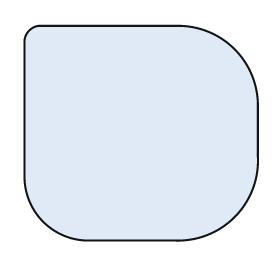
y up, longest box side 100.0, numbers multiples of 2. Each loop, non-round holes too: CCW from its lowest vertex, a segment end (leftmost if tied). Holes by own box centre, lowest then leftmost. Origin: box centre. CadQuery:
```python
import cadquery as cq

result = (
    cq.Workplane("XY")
    .moveTo(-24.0, -46.0)
    .lineTo(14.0, -46.0)
    .threePointArc((40.0, -36.0), (50.0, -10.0))
    .lineTo(50.0, 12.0)
    .threePointArc((40.0, 36.0), (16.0, 46.0))
    .lineTo(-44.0, 46.0)
    .threePointArc((-48.0, 44.0), (-50.0, 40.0))
    .lineTo(-50.0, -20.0)
    .threePointArc((-42.0, -38.0), (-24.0, -46.0))
    .close()
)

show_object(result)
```